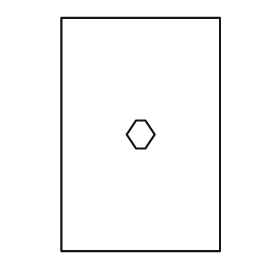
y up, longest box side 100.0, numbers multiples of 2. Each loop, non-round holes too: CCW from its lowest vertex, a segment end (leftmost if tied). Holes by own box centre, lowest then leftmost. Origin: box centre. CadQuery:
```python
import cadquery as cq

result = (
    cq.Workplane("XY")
    .moveTo(-34.0, -50.0)
    .lineTo(34.0, -50.0)
    .lineTo(34.0, 50.0)
    .lineTo(-34.0, 50.0)
    .close()
    .moveTo(-2.0, -6.0)
    .lineTo(2.0, -6.0)
    .lineTo(6.0, 0.0)
    .lineTo(2.0, 6.0)
    .lineTo(-2.0, 6.0)
    .lineTo(-6.0, 0.0)
    .close()
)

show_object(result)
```